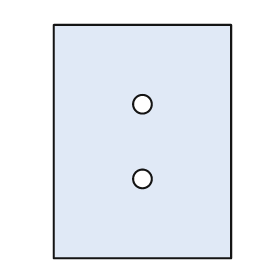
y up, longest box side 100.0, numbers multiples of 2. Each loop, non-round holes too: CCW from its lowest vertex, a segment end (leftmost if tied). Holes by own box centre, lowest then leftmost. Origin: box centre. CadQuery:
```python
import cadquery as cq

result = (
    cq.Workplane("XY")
    .moveTo(-38.0, -50.0)
    .lineTo(38.0, -50.0)
    .lineTo(38.0, 50.0)
    .lineTo(-38.0, 50.0)
    .close()
    .moveTo(0.0, -16.0)
    .circle(4.0)
    .moveTo(0.0, 16.0)
    .circle(4.0)
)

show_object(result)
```